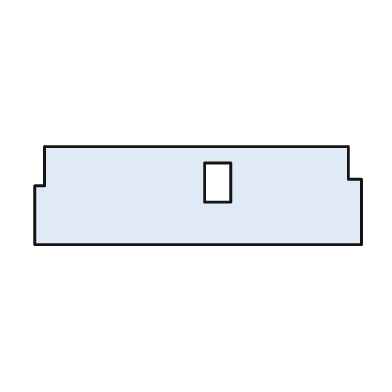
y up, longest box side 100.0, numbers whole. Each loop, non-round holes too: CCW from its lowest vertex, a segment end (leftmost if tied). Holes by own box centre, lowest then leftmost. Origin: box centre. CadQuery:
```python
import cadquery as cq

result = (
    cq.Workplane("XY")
    .moveTo(-50.0, -15.0)
    .lineTo(50.0, -15.0)
    .lineTo(50.0, 5.0)
    .lineTo(46.0, 5.0)
    .lineTo(46.0, 15.0)
    .lineTo(-47.0, 15.0)
    .lineTo(-47.0, 3.0)
    .lineTo(-50.0, 3.0)
    .close()
    .moveTo(2.0, -2.0)
    .lineTo(10.0, -2.0)
    .lineTo(10.0, 10.0)
    .lineTo(2.0, 10.0)
    .close()
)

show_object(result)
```